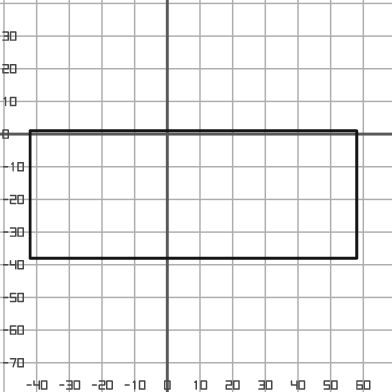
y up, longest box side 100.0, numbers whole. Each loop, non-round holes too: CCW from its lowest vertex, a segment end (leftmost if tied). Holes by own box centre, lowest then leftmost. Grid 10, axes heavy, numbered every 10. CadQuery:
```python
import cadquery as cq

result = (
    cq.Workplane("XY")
    .moveTo(-42.0, -38.0)
    .lineTo(58.0, -38.0)
    .lineTo(58.0, 1.0)
    .lineTo(-42.0, 1.0)
    .close()
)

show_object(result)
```